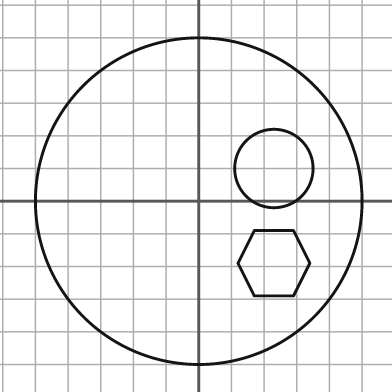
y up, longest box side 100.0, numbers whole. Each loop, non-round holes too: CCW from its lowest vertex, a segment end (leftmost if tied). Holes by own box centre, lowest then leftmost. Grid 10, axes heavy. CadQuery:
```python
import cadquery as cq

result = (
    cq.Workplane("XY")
    .moveTo(0.0, 0.0)
    .circle(50.0)
    .moveTo(17.0, -29.0)
    .lineTo(29.0, -29.0)
    .lineTo(34.0, -19.0)
    .lineTo(29.0, -9.0)
    .lineTo(17.0, -9.0)
    .lineTo(12.0, -19.0)
    .close()
    .moveTo(23.0, 10.0)
    .circle(12.0)
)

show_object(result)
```